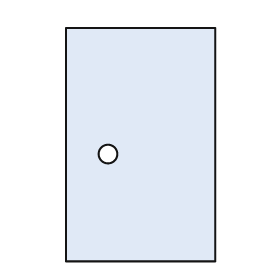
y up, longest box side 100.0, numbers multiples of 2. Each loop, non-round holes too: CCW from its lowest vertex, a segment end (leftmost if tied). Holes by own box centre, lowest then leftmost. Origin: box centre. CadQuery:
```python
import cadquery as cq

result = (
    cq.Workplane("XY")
    .moveTo(-32.0, -50.0)
    .lineTo(32.0, -50.0)
    .lineTo(32.0, 50.0)
    .lineTo(-32.0, 50.0)
    .close()
    .moveTo(-14.0, -4.0)
    .circle(4.0)
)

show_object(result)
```